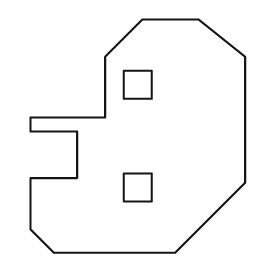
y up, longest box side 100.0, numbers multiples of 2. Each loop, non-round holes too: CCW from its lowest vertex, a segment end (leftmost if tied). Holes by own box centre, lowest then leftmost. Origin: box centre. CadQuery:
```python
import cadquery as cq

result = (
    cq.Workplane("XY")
    .moveTo(-36.0, -50.0)
    .lineTo(16.0, -50.0)
    .lineTo(46.0, -20.0)
    .lineTo(46.0, 34.0)
    .lineTo(26.0, 50.0)
    .lineTo(2.0, 50.0)
    .lineTo(-14.0, 34.0)
    .lineTo(-14.0, 8.0)
    .lineTo(-46.0, 8.0)
    .lineTo(-46.0, 2.0)
    .lineTo(-26.0, 2.0)
    .lineTo(-26.0, -18.0)
    .lineTo(-46.0, -18.0)
    .lineTo(-46.0, -40.0)
    .close()
    .moveTo(-6.0, -28.0)
    .lineTo(6.0, -28.0)
    .lineTo(6.0, -16.0)
    .lineTo(-6.0, -16.0)
    .close()
    .moveTo(-6.0, 16.0)
    .lineTo(6.0, 16.0)
    .lineTo(6.0, 28.0)
    .lineTo(-6.0, 28.0)
    .close()
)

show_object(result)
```